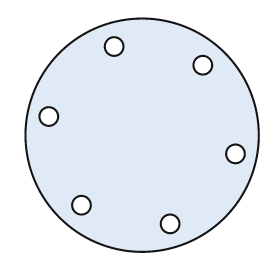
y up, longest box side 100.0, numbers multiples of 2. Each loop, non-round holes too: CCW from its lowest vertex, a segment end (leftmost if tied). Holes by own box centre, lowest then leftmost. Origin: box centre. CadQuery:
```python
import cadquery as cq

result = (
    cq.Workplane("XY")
    .moveTo(0.0, 0.0)
    .circle(50.0)
    .moveTo(12.0, -38.0)
    .circle(4.0)
    .moveTo(-26.0, -30.0)
    .circle(4.0)
    .moveTo(40.0, -8.0)
    .circle(4.0)
    .moveTo(-40.0, 8.0)
    .circle(4.0)
    .moveTo(26.0, 30.0)
    .circle(4.0)
    .moveTo(-12.0, 38.0)
    .circle(4.0)
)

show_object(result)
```